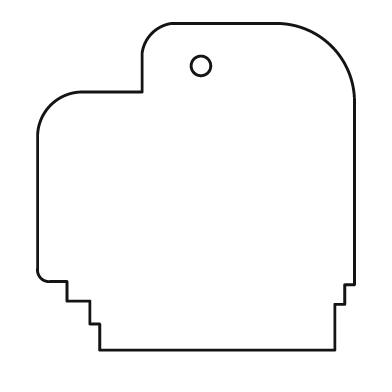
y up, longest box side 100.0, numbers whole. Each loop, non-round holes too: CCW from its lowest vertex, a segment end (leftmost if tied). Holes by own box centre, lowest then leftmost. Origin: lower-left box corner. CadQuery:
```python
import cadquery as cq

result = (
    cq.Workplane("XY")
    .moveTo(19.0, 0.0)
    .lineTo(91.0, 0.0)
    .lineTo(91.0, 14.0)
    .lineTo(94.0, 14.0)
    .lineTo(94.0, 20.0)
    .lineTo(97.0, 20.0)
    .lineTo(97.0, 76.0)
    .threePointArc((90.0, 93.0), (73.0, 100.0))
    .lineTo(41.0, 100.0)
    .threePointArc((35.0, 97.0), (32.0, 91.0))
    .lineTo(32.0, 79.0)
    .lineTo(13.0, 79.0)
    .threePointArc((4.0, 75.0), (0.0, 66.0))
    .lineTo(0.0, 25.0)
    .threePointArc((1.0, 22.0), (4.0, 21.0))
    .lineTo(9.0, 21.0)
    .lineTo(9.0, 15.0)
    .lineTo(16.0, 15.0)
    .lineTo(16.0, 8.0)
    .lineTo(19.0, 8.0)
    .close()
    .moveTo(50.0, 87.0)
    .circle(3.0)
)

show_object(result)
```